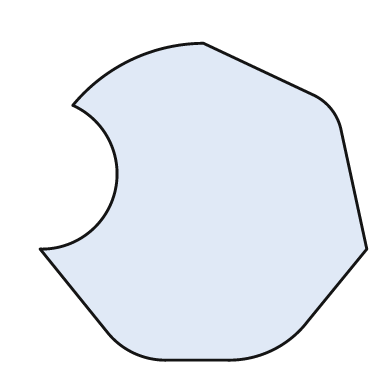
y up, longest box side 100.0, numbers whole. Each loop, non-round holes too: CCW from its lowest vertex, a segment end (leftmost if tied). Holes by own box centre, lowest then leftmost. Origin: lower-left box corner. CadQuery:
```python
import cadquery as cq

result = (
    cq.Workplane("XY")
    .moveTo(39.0, 0.0)
    .lineTo(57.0, 0.0)
    .threePointArc((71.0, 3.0), (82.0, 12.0))
    .lineTo(100.0, 34.0)
    .lineTo(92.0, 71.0)
    .threePointArc((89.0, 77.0), (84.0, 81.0))
    .lineTo(50.0, 97.0)
    .threePointArc((28.0, 92.0), (10.0, 78.0))
    .threePointArc((23.0, 52.0), (0.0, 34.0))
    .lineTo(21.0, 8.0)
    .threePointArc((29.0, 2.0), (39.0, 0.0))
    .close()
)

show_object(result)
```